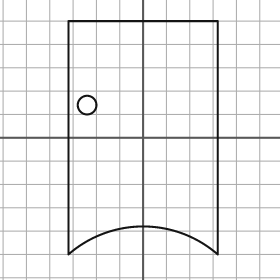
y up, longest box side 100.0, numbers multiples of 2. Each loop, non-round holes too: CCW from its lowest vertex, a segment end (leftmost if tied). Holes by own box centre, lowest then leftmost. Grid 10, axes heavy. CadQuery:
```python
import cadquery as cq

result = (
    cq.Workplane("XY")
    .moveTo(-32.0, -50.0)
    .threePointArc((0.0, -38.0), (32.0, -50.0))
    .lineTo(32.0, 50.0)
    .lineTo(-32.0, 50.0)
    .close()
    .moveTo(-24.0, 14.0)
    .circle(4.0)
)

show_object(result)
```